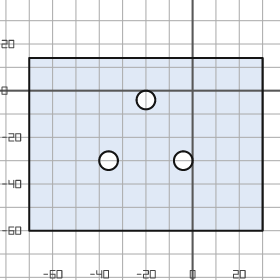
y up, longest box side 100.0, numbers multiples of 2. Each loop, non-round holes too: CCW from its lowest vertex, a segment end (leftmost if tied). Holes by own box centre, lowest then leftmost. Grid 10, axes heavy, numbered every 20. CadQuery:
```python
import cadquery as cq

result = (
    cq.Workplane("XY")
    .moveTo(-70.0, -60.0)
    .lineTo(30.0, -60.0)
    .lineTo(30.0, 14.0)
    .lineTo(-70.0, 14.0)
    .close()
    .moveTo(-36.0, -30.0)
    .circle(4.0)
    .moveTo(-4.0, -30.0)
    .circle(4.0)
    .moveTo(-20.0, -4.0)
    .circle(4.0)
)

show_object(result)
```